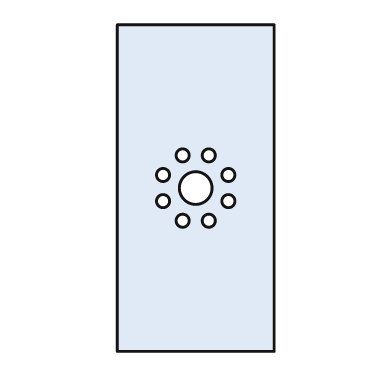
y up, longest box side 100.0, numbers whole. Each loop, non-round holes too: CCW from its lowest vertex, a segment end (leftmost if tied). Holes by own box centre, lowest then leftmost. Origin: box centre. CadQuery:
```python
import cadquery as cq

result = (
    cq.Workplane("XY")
    .moveTo(-24.0, -50.0)
    .lineTo(24.0, -50.0)
    .lineTo(24.0, 50.0)
    .lineTo(-24.0, 50.0)
    .close()
    .moveTo(-4.0, -10.0)
    .circle(2.0)
    .moveTo(4.0, -10.0)
    .circle(2.0)
    .moveTo(-10.0, -4.0)
    .circle(2.0)
    .moveTo(10.0, -4.0)
    .circle(2.0)
    .moveTo(0.0, 0.0)
    .circle(5.0)
    .moveTo(-10.0, 4.0)
    .circle(2.0)
    .moveTo(10.0, 4.0)
    .circle(2.0)
    .moveTo(-4.0, 10.0)
    .circle(2.0)
    .moveTo(4.0, 10.0)
    .circle(2.0)
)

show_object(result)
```